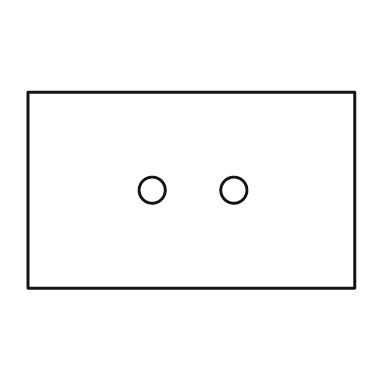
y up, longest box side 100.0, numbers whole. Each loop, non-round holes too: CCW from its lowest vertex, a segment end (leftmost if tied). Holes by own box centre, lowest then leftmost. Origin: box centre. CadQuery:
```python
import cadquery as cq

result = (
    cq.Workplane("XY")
    .moveTo(-50.0, -30.0)
    .lineTo(50.0, -30.0)
    .lineTo(50.0, 30.0)
    .lineTo(-50.0, 30.0)
    .close()
    .moveTo(-12.0, 0.0)
    .circle(4.0)
    .moveTo(13.0, 0.0)
    .circle(4.0)
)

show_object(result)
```